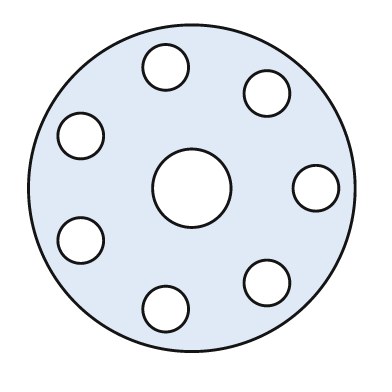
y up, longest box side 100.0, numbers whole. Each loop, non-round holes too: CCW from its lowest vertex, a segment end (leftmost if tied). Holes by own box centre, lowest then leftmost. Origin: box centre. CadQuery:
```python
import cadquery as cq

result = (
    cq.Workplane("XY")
    .moveTo(0.0, 0.0)
    .circle(50.0)
    .moveTo(-8.0, -37.0)
    .circle(7.0)
    .moveTo(23.0, -29.0)
    .circle(7.0)
    .moveTo(-34.0, -16.0)
    .circle(7.0)
    .moveTo(0.0, 0.0)
    .circle(12.0)
    .moveTo(38.0, 0.0)
    .circle(7.0)
    .moveTo(-34.0, 16.0)
    .circle(7.0)
    .moveTo(23.0, 29.0)
    .circle(7.0)
    .moveTo(-8.0, 37.0)
    .circle(7.0)
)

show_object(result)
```